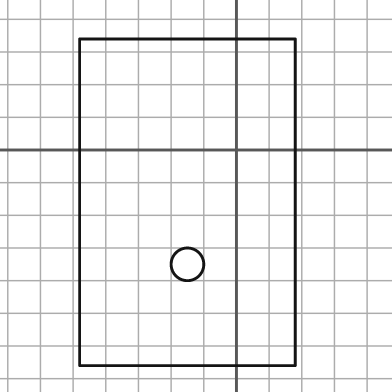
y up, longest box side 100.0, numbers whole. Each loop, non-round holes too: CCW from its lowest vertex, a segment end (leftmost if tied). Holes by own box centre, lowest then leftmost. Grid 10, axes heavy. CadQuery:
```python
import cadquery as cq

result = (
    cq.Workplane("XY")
    .moveTo(-48.0, -66.0)
    .lineTo(18.0, -66.0)
    .lineTo(18.0, 34.0)
    .lineTo(-48.0, 34.0)
    .close()
    .moveTo(-15.0, -35.0)
    .circle(5.0)
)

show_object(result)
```